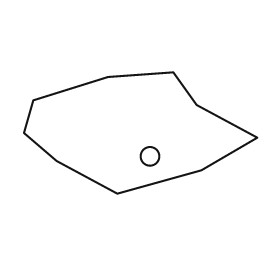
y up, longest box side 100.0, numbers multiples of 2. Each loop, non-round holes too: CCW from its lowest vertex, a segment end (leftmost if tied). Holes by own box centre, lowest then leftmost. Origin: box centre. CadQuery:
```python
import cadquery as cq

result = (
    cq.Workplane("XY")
    .moveTo(-10.0, -26.0)
    .lineTo(26.0, -16.0)
    .lineTo(50.0, -2.0)
    .lineTo(24.0, 12.0)
    .lineTo(14.0, 26.0)
    .lineTo(-14.0, 24.0)
    .lineTo(-46.0, 14.0)
    .lineTo(-50.0, 0.0)
    .lineTo(-36.0, -12.0)
    .close()
    .moveTo(4.0, -10.0)
    .circle(4.0)
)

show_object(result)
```